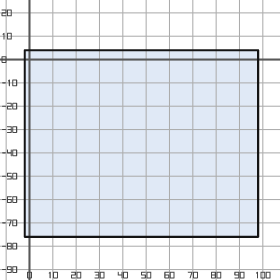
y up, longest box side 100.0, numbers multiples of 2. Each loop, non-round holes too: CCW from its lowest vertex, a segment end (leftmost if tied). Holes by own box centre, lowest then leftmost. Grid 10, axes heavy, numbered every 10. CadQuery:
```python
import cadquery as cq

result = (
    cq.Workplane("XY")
    .moveTo(-2.0, -76.0)
    .lineTo(98.0, -76.0)
    .lineTo(98.0, 4.0)
    .lineTo(-2.0, 4.0)
    .close()
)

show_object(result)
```